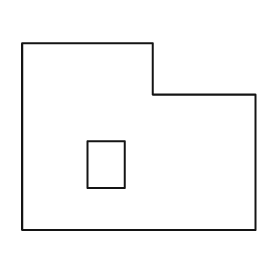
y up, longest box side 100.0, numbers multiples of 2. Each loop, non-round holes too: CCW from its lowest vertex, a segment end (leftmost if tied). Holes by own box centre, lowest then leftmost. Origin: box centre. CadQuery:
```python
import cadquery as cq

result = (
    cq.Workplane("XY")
    .moveTo(-50.0, -40.0)
    .lineTo(50.0, -40.0)
    .lineTo(50.0, 18.0)
    .lineTo(6.0, 18.0)
    .lineTo(6.0, 40.0)
    .lineTo(-50.0, 40.0)
    .close()
    .moveTo(-22.0, -22.0)
    .lineTo(-6.0, -22.0)
    .lineTo(-6.0, -2.0)
    .lineTo(-22.0, -2.0)
    .close()
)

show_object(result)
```